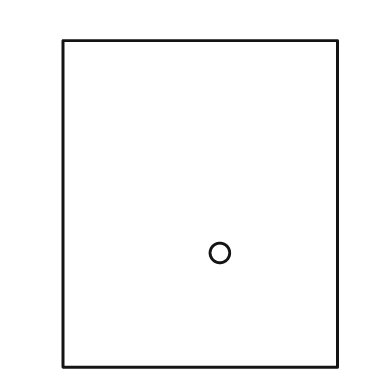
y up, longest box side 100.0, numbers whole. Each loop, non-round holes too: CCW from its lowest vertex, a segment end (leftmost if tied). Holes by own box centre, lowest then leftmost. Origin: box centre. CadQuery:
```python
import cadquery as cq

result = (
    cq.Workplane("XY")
    .moveTo(-42.0, -50.0)
    .lineTo(42.0, -50.0)
    .lineTo(42.0, 50.0)
    .lineTo(-42.0, 50.0)
    .close()
    .moveTo(6.0, -15.0)
    .circle(3.0)
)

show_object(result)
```